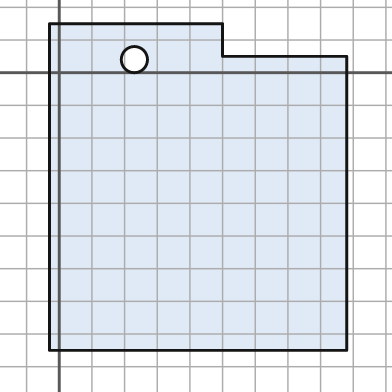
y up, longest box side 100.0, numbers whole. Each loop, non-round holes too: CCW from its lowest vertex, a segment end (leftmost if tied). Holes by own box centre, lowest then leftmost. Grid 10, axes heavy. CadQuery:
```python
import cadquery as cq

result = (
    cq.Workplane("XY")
    .moveTo(-3.0, -85.0)
    .lineTo(88.0, -85.0)
    .lineTo(88.0, 5.0)
    .lineTo(50.0, 5.0)
    .lineTo(50.0, 15.0)
    .lineTo(-3.0, 15.0)
    .close()
    .moveTo(23.0, 4.0)
    .circle(4.0)
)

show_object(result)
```